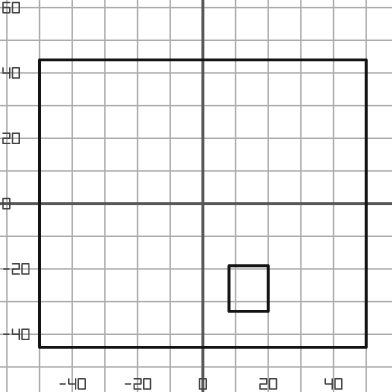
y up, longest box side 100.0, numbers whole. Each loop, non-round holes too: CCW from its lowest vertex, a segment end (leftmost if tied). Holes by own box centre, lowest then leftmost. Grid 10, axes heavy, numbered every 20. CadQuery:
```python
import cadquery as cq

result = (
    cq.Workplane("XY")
    .moveTo(-50.0, -44.0)
    .lineTo(50.0, -44.0)
    .lineTo(50.0, 44.0)
    .lineTo(-50.0, 44.0)
    .close()
    .moveTo(8.0, -33.0)
    .lineTo(20.0, -33.0)
    .lineTo(20.0, -19.0)
    .lineTo(8.0, -19.0)
    .close()
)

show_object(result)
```